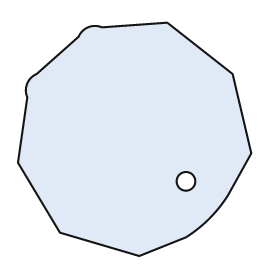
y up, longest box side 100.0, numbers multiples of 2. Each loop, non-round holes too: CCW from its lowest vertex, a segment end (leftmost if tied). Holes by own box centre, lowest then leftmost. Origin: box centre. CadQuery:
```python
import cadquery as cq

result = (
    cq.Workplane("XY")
    .moveTo(2.0, -50.0)
    .lineTo(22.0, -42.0)
    .threePointArc((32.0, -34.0), (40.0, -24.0))
    .lineTo(50.0, -6.0)
    .lineTo(42.0, 28.0)
    .lineTo(14.0, 50.0)
    .lineTo(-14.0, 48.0)
    .threePointArc((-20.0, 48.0), (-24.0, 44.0))
    .lineTo(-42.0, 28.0)
    .threePointArc((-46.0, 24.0), (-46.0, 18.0))
    .lineTo(-50.0, -10.0)
    .lineTo(-32.0, -40.0)
    .close()
    .moveTo(22.0, -18.0)
    .circle(4.0)
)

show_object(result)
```